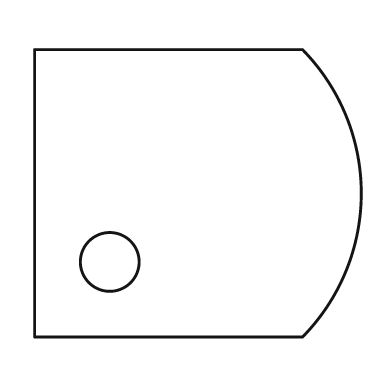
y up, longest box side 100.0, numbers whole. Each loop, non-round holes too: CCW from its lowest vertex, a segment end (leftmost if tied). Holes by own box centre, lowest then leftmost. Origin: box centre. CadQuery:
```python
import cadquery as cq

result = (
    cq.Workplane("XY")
    .moveTo(-50.0, -44.0)
    .lineTo(32.0, -44.0)
    .threePointArc((50.0, 0.0), (32.0, 44.0))
    .lineTo(-50.0, 44.0)
    .close()
    .moveTo(-27.0, -21.0)
    .circle(9.0)
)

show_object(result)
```